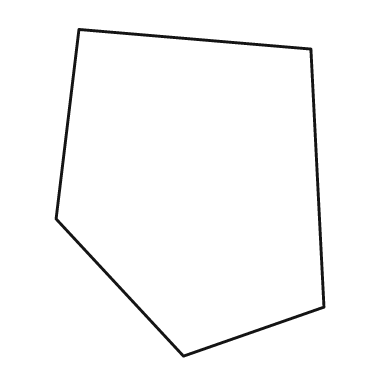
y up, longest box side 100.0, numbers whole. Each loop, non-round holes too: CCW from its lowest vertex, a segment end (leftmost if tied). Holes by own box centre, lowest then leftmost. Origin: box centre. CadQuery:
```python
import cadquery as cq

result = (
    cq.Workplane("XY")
    .moveTo(-2.0, -50.0)
    .lineTo(41.0, -35.0)
    .lineTo(37.0, 44.0)
    .lineTo(-34.0, 50.0)
    .lineTo(-41.0, -8.0)
    .close()
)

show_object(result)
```